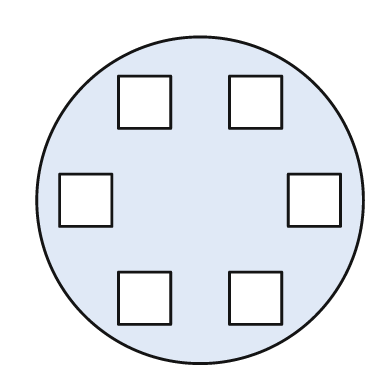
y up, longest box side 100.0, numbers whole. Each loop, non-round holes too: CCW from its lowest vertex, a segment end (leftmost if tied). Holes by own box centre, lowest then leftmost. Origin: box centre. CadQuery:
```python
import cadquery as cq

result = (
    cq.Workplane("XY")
    .moveTo(0.0, 0.0)
    .circle(50.0)
    .moveTo(-25.0, -38.0)
    .lineTo(-9.0, -38.0)
    .lineTo(-9.0, -22.0)
    .lineTo(-25.0, -22.0)
    .close()
    .moveTo(9.0, -38.0)
    .lineTo(25.0, -38.0)
    .lineTo(25.0, -22.0)
    .lineTo(9.0, -22.0)
    .close()
    .moveTo(-43.0, -8.0)
    .lineTo(-27.0, -8.0)
    .lineTo(-27.0, 8.0)
    .lineTo(-43.0, 8.0)
    .close()
    .moveTo(27.0, -8.0)
    .lineTo(43.0, -8.0)
    .lineTo(43.0, 8.0)
    .lineTo(27.0, 8.0)
    .close()
    .moveTo(-25.0, 22.0)
    .lineTo(-9.0, 22.0)
    .lineTo(-9.0, 38.0)
    .lineTo(-25.0, 38.0)
    .close()
    .moveTo(9.0, 22.0)
    .lineTo(25.0, 22.0)
    .lineTo(25.0, 38.0)
    .lineTo(9.0, 38.0)
    .close()
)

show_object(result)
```